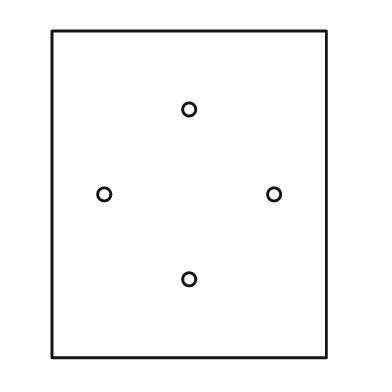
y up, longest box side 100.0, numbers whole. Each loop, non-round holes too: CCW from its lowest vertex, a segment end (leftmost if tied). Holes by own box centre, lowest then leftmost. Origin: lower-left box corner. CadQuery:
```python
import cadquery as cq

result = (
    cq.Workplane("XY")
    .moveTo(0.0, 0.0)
    .lineTo(84.0, 0.0)
    .lineTo(84.0, 100.0)
    .lineTo(0.0, 100.0)
    .close()
    .moveTo(42.0, 24.0)
    .circle(2.0)
    .moveTo(16.0, 50.0)
    .circle(2.0)
    .moveTo(68.0, 50.0)
    .circle(2.0)
    .moveTo(42.0, 76.0)
    .circle(2.0)
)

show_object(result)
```